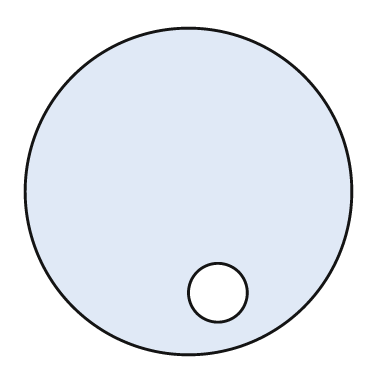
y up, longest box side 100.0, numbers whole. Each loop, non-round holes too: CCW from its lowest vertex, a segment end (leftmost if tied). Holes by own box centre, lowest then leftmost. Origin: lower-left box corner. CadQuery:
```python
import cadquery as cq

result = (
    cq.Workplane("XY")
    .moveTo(50.0, 50.0)
    .circle(50.0)
    .moveTo(59.0, 19.0)
    .circle(9.0)
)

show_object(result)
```